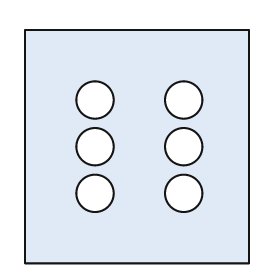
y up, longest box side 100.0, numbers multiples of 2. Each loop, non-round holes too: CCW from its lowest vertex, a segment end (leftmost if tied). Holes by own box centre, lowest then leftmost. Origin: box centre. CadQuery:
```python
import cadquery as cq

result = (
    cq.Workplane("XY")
    .moveTo(-48.0, -50.0)
    .lineTo(48.0, -50.0)
    .lineTo(48.0, 50.0)
    .lineTo(-48.0, 50.0)
    .close()
    .moveTo(-18.0, -20.0)
    .circle(8.0)
    .moveTo(20.0, -20.0)
    .circle(8.0)
    .moveTo(-18.0, 0.0)
    .circle(8.0)
    .moveTo(20.0, 0.0)
    .circle(8.0)
    .moveTo(-18.0, 20.0)
    .circle(8.0)
    .moveTo(20.0, 20.0)
    .circle(8.0)
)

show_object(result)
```